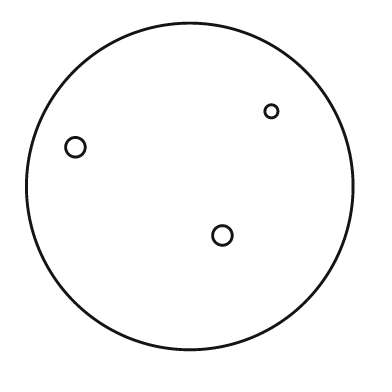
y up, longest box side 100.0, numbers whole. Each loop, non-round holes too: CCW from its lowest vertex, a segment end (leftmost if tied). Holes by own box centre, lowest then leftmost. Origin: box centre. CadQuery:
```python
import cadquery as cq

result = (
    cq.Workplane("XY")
    .moveTo(0.0, 0.0)
    .circle(50.0)
    .moveTo(10.0, -15.0)
    .circle(3.0)
    .moveTo(-35.0, 12.0)
    .circle(3.0)
    .moveTo(25.0, 23.0)
    .circle(2.0)
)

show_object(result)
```